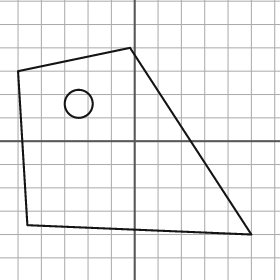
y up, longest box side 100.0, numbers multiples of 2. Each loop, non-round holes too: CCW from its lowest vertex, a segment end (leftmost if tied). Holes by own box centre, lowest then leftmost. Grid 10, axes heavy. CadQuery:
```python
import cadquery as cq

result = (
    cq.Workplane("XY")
    .moveTo(50.0, -40.0)
    .lineTo(-2.0, 40.0)
    .lineTo(-50.0, 30.0)
    .lineTo(-46.0, -36.0)
    .close()
    .moveTo(-24.0, 16.0)
    .circle(6.0)
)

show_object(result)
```